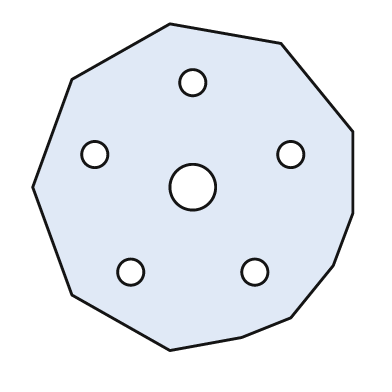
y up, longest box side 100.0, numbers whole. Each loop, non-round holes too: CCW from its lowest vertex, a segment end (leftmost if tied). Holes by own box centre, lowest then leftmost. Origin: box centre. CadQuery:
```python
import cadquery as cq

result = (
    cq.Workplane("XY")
    .moveTo(-7.0, -50.0)
    .lineTo(15.0, -46.0)
    .lineTo(30.0, -40.0)
    .lineTo(43.0, -24.0)
    .lineTo(49.0, -8.0)
    .lineTo(49.0, 17.0)
    .lineTo(27.0, 44.0)
    .lineTo(-7.0, 50.0)
    .lineTo(-37.0, 33.0)
    .lineTo(-49.0, 0.0)
    .lineTo(-37.0, -33.0)
    .close()
    .moveTo(-19.0, -26.0)
    .circle(4.0)
    .moveTo(19.0, -26.0)
    .circle(4.0)
    .moveTo(0.0, 0.0)
    .circle(7.0)
    .moveTo(-30.0, 10.0)
    .circle(4.0)
    .moveTo(30.0, 10.0)
    .circle(4.0)
    .moveTo(0.0, 32.0)
    .circle(4.0)
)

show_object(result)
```